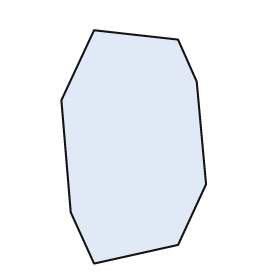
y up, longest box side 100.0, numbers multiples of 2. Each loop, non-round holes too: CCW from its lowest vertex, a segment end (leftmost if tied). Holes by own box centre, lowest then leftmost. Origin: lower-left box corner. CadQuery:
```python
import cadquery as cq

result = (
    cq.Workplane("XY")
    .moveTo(14.0, 0.0)
    .lineTo(50.0, 8.0)
    .lineTo(62.0, 34.0)
    .lineTo(58.0, 78.0)
    .lineTo(50.0, 96.0)
    .lineTo(14.0, 100.0)
    .lineTo(0.0, 70.0)
    .lineTo(4.0, 22.0)
    .close()
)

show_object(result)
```